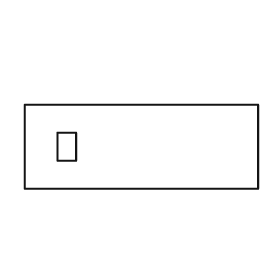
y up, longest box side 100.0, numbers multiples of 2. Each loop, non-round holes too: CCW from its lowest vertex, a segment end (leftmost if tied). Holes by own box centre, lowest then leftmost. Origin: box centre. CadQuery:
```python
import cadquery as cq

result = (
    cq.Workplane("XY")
    .moveTo(-50.0, -18.0)
    .lineTo(50.0, -18.0)
    .lineTo(50.0, 18.0)
    .lineTo(-50.0, 18.0)
    .close()
    .moveTo(-36.0, -6.0)
    .lineTo(-28.0, -6.0)
    .lineTo(-28.0, 6.0)
    .lineTo(-36.0, 6.0)
    .close()
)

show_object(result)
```